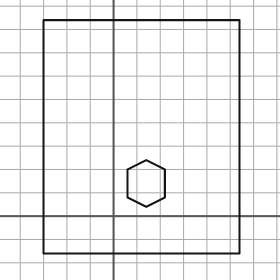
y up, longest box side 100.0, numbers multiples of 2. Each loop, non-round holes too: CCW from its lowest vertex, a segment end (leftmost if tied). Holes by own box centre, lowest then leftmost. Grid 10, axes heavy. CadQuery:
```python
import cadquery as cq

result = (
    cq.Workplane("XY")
    .moveTo(-30.0, -16.0)
    .lineTo(54.0, -16.0)
    .lineTo(54.0, 84.0)
    .lineTo(-30.0, 84.0)
    .close()
    .moveTo(14.0, 4.0)
    .lineTo(22.0, 8.0)
    .lineTo(22.0, 20.0)
    .lineTo(14.0, 24.0)
    .lineTo(6.0, 20.0)
    .lineTo(6.0, 8.0)
    .close()
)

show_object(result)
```